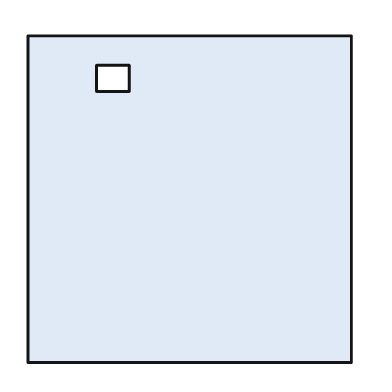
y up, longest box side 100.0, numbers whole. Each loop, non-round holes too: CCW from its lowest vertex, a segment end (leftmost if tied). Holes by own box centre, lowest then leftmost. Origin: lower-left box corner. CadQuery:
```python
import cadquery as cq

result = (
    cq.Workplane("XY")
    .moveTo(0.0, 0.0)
    .lineTo(99.0, 0.0)
    .lineTo(99.0, 100.0)
    .lineTo(0.0, 100.0)
    .close()
    .moveTo(21.0, 83.0)
    .lineTo(31.0, 83.0)
    .lineTo(31.0, 91.0)
    .lineTo(21.0, 91.0)
    .close()
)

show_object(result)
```